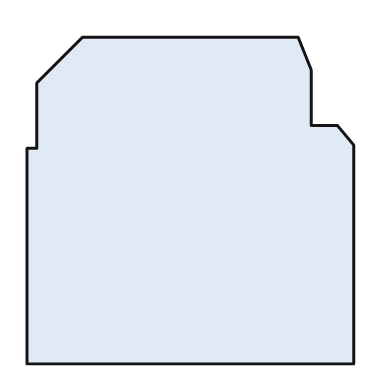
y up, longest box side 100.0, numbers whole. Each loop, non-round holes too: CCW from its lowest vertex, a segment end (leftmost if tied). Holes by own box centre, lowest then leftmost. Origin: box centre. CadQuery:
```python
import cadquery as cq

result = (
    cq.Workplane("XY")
    .moveTo(-50.0, -50.0)
    .lineTo(50.0, -50.0)
    .lineTo(50.0, 17.0)
    .lineTo(45.0, 23.0)
    .lineTo(37.0, 23.0)
    .lineTo(37.0, 40.0)
    .lineTo(33.0, 50.0)
    .lineTo(-33.0, 50.0)
    .lineTo(-47.0, 36.0)
    .lineTo(-47.0, 16.0)
    .lineTo(-50.0, 16.0)
    .close()
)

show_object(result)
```